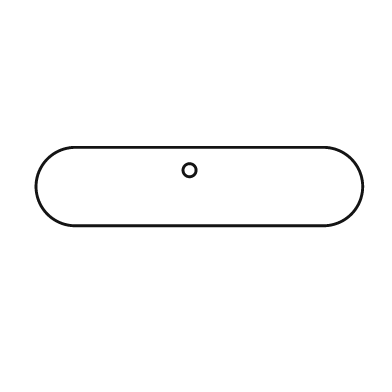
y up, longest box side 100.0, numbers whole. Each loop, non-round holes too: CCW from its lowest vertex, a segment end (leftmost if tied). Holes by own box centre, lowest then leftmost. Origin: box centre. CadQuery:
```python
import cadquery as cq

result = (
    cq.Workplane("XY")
    .moveTo(-38.0, -12.0)
    .lineTo(38.0, -12.0)
    .threePointArc((50.0, 0.0), (38.0, 12.0))
    .lineTo(-38.0, 12.0)
    .threePointArc((-50.0, 0.0), (-38.0, -12.0))
    .close()
    .moveTo(-3.0, 5.0)
    .circle(2.0)
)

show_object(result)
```